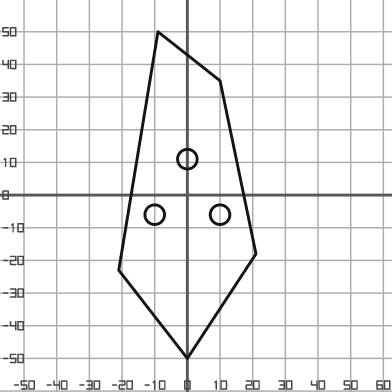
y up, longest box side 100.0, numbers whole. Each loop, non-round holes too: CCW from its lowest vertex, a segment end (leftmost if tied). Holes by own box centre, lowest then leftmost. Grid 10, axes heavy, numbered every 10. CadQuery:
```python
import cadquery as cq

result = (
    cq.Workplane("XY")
    .moveTo(0.0, -50.0)
    .lineTo(21.0, -18.0)
    .lineTo(10.0, 35.0)
    .lineTo(-9.0, 50.0)
    .lineTo(-21.0, -23.0)
    .close()
    .moveTo(-10.0, -6.0)
    .circle(3.0)
    .moveTo(10.0, -6.0)
    .circle(3.0)
    .moveTo(0.0, 11.0)
    .circle(3.0)
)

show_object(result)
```